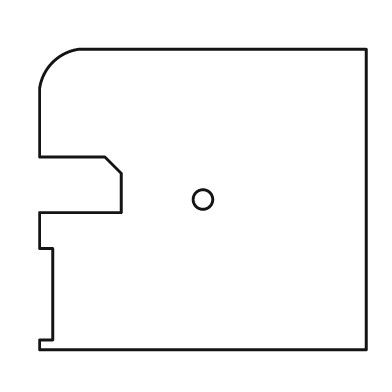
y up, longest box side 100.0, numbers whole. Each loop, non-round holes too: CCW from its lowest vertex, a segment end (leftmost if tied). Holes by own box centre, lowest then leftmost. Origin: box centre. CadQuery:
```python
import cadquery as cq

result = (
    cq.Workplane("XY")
    .moveTo(-50.0, -46.0)
    .lineTo(50.0, -46.0)
    .lineTo(50.0, 46.0)
    .lineTo(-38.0, 46.0)
    .threePointArc((-46.0, 42.0), (-50.0, 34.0))
    .lineTo(-50.0, 13.0)
    .lineTo(-30.0, 13.0)
    .lineTo(-25.0, 8.0)
    .lineTo(-25.0, -4.0)
    .lineTo(-50.0, -4.0)
    .lineTo(-50.0, -15.0)
    .lineTo(-46.0, -15.0)
    .lineTo(-46.0, -43.0)
    .lineTo(-50.0, -43.0)
    .close()
    .moveTo(0.0, 0.0)
    .circle(3.0)
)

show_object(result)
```